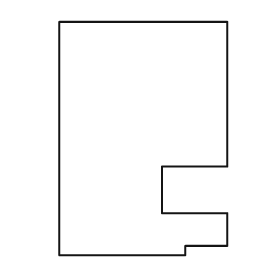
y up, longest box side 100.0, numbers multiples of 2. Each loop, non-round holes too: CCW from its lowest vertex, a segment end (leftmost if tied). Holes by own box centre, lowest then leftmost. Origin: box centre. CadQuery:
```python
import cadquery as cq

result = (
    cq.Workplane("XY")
    .moveTo(-36.0, -50.0)
    .lineTo(18.0, -50.0)
    .lineTo(18.0, -46.0)
    .lineTo(36.0, -46.0)
    .lineTo(36.0, -32.0)
    .lineTo(8.0, -32.0)
    .lineTo(8.0, -12.0)
    .lineTo(36.0, -12.0)
    .lineTo(36.0, 50.0)
    .lineTo(-36.0, 50.0)
    .close()
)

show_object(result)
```